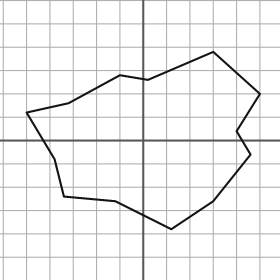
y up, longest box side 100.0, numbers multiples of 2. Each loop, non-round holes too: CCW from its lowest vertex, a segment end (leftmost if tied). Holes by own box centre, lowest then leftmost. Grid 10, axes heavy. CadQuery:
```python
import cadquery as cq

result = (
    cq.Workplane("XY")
    .moveTo(12.0, -38.0)
    .lineTo(30.0, -26.0)
    .lineTo(46.0, -6.0)
    .lineTo(40.0, 4.0)
    .lineTo(50.0, 20.0)
    .lineTo(30.0, 38.0)
    .lineTo(2.0, 26.0)
    .lineTo(-10.0, 28.0)
    .lineTo(-32.0, 16.0)
    .lineTo(-50.0, 12.0)
    .lineTo(-38.0, -8.0)
    .lineTo(-34.0, -24.0)
    .lineTo(-12.0, -26.0)
    .close()
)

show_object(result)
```